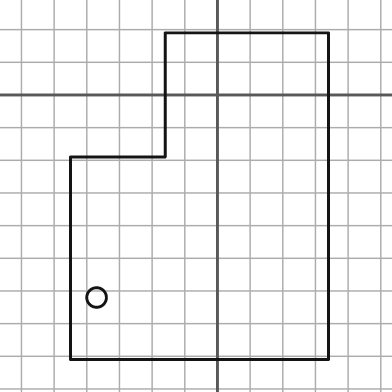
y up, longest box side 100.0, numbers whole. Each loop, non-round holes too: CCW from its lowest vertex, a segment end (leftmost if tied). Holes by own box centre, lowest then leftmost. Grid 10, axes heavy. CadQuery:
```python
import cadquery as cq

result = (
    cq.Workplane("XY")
    .moveTo(-45.0, -81.0)
    .lineTo(34.0, -81.0)
    .lineTo(34.0, 19.0)
    .lineTo(-16.0, 19.0)
    .lineTo(-16.0, -19.0)
    .lineTo(-45.0, -19.0)
    .close()
    .moveTo(-37.0, -62.0)
    .circle(3.0)
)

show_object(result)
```